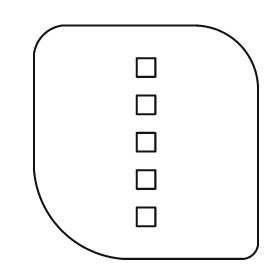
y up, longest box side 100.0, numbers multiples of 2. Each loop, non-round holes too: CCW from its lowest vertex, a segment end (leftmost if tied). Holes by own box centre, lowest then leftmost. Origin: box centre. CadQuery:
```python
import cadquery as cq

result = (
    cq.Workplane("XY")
    .moveTo(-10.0, -50.0)
    .lineTo(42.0, -50.0)
    .threePointArc((46.0, -48.0), (48.0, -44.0))
    .lineTo(48.0, 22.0)
    .threePointArc((40.0, 42.0), (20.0, 50.0))
    .lineTo(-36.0, 50.0)
    .threePointArc((-44.0, 46.0), (-48.0, 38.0))
    .lineTo(-48.0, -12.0)
    .threePointArc((-36.0, -38.0), (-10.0, -50.0))
    .close()
    .moveTo(-4.0, -36.0)
    .lineTo(4.0, -36.0)
    .lineTo(4.0, -28.0)
    .lineTo(-4.0, -28.0)
    .close()
    .moveTo(-4.0, -20.0)
    .lineTo(4.0, -20.0)
    .lineTo(4.0, -12.0)
    .lineTo(-4.0, -12.0)
    .close()
    .moveTo(-4.0, -4.0)
    .lineTo(4.0, -4.0)
    .lineTo(4.0, 4.0)
    .lineTo(-4.0, 4.0)
    .close()
    .moveTo(-4.0, 12.0)
    .lineTo(4.0, 12.0)
    .lineTo(4.0, 20.0)
    .lineTo(-4.0, 20.0)
    .close()
    .moveTo(-4.0, 28.0)
    .lineTo(4.0, 28.0)
    .lineTo(4.0, 36.0)
    .lineTo(-4.0, 36.0)
    .close()
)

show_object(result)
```